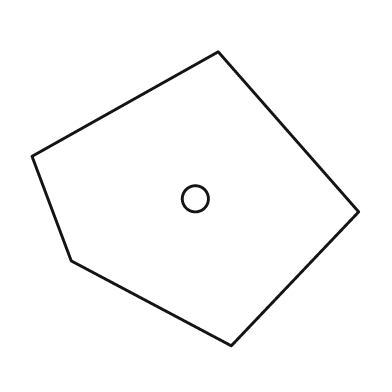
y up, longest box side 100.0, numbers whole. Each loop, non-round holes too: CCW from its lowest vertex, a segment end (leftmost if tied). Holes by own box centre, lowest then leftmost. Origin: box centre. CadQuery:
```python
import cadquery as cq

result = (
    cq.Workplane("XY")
    .moveTo(11.0, -45.0)
    .lineTo(50.0, -4.0)
    .lineTo(7.0, 45.0)
    .lineTo(-50.0, 13.0)
    .lineTo(-38.0, -19.0)
    .close()
    .moveTo(0.0, 0.0)
    .circle(4.0)
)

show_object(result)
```